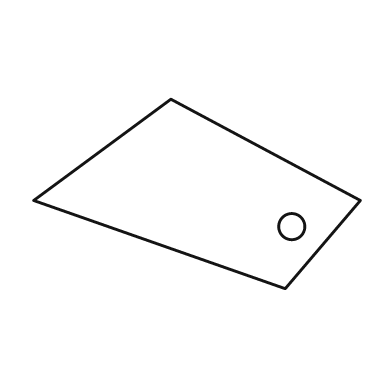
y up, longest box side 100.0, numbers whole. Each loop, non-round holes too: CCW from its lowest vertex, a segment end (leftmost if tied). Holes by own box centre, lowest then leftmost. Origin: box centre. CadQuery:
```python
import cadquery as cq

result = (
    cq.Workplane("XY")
    .moveTo(27.0, -29.0)
    .lineTo(50.0, -2.0)
    .lineTo(-8.0, 29.0)
    .lineTo(-50.0, -2.0)
    .close()
    .moveTo(29.0, -10.0)
    .circle(4.0)
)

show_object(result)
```